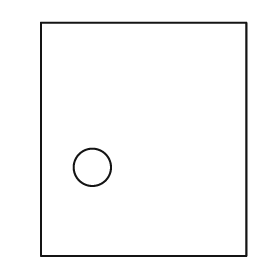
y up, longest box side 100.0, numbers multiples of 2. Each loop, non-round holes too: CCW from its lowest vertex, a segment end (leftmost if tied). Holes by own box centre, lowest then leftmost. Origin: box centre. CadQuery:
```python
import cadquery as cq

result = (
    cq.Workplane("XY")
    .moveTo(-44.0, -50.0)
    .lineTo(44.0, -50.0)
    .lineTo(44.0, 50.0)
    .lineTo(-44.0, 50.0)
    .close()
    .moveTo(-22.0, -12.0)
    .circle(8.0)
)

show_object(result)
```